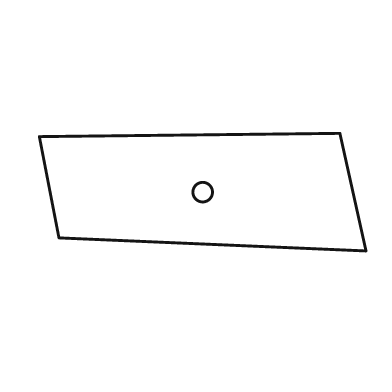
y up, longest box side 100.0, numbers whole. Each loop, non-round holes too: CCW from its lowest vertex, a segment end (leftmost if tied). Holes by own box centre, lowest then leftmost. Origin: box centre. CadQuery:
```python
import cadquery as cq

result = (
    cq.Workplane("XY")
    .moveTo(50.0, -18.0)
    .lineTo(42.0, 18.0)
    .lineTo(-50.0, 17.0)
    .lineTo(-44.0, -14.0)
    .close()
    .moveTo(0.0, 0.0)
    .circle(3.0)
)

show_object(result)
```